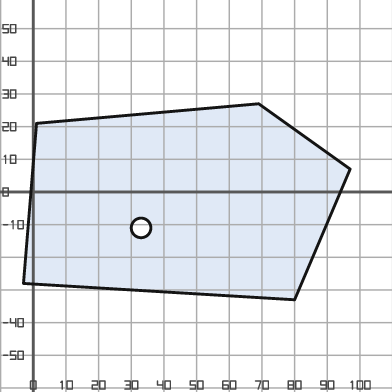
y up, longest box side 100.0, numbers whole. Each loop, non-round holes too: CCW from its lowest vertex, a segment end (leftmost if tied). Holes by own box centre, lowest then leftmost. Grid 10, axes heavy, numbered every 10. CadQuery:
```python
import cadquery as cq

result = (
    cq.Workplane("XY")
    .moveTo(80.0, -33.0)
    .lineTo(97.0, 7.0)
    .lineTo(69.0, 27.0)
    .lineTo(1.0, 21.0)
    .lineTo(-3.0, -28.0)
    .close()
    .moveTo(33.0, -11.0)
    .circle(3.0)
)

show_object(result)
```